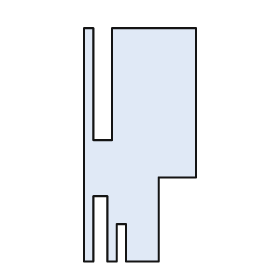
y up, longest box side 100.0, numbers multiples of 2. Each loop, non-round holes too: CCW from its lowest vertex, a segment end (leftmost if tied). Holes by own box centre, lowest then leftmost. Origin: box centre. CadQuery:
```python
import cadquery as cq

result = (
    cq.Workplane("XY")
    .moveTo(-24.0, -50.0)
    .lineTo(-20.0, -50.0)
    .lineTo(-20.0, -22.0)
    .lineTo(-14.0, -22.0)
    .lineTo(-14.0, -50.0)
    .lineTo(-10.0, -50.0)
    .lineTo(-10.0, -34.0)
    .lineTo(-6.0, -34.0)
    .lineTo(-6.0, -50.0)
    .lineTo(8.0, -50.0)
    .lineTo(8.0, -14.0)
    .lineTo(24.0, -14.0)
    .lineTo(24.0, 50.0)
    .lineTo(-12.0, 50.0)
    .lineTo(-12.0, 2.0)
    .lineTo(-20.0, 2.0)
    .lineTo(-20.0, 50.0)
    .lineTo(-24.0, 50.0)
    .close()
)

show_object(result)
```